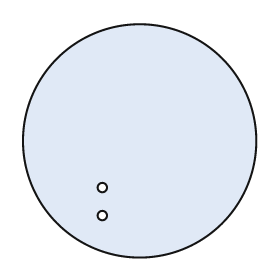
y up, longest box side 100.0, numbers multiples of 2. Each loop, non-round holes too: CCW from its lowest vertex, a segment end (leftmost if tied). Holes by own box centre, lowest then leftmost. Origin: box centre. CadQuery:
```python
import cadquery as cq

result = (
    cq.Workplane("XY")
    .moveTo(0.0, 0.0)
    .circle(50.0)
    .moveTo(-16.0, -32.0)
    .circle(2.0)
    .moveTo(-16.0, -20.0)
    .circle(2.0)
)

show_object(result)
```